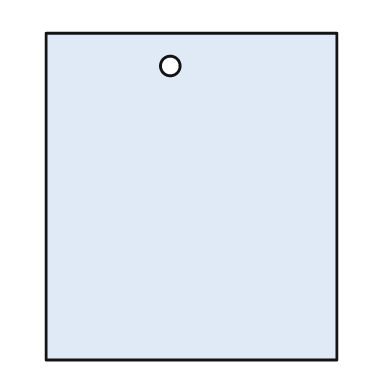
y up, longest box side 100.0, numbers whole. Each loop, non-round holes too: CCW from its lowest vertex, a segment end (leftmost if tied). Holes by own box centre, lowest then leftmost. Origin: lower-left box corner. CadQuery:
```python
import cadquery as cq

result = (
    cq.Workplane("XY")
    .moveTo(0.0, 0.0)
    .lineTo(89.0, 0.0)
    .lineTo(89.0, 100.0)
    .lineTo(0.0, 100.0)
    .close()
    .moveTo(38.0, 90.0)
    .circle(3.0)
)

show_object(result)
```